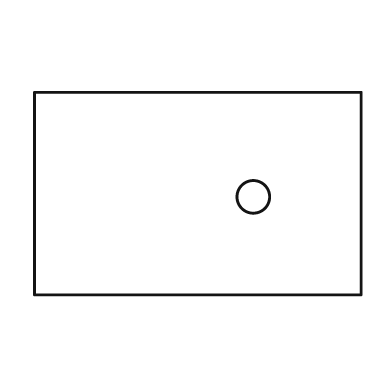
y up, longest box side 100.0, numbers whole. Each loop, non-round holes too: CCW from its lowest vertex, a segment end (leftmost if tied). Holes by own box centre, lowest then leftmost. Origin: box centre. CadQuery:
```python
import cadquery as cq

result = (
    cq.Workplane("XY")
    .moveTo(-50.0, -31.0)
    .lineTo(50.0, -31.0)
    .lineTo(50.0, 31.0)
    .lineTo(-50.0, 31.0)
    .close()
    .moveTo(17.0, -1.0)
    .circle(5.0)
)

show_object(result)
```